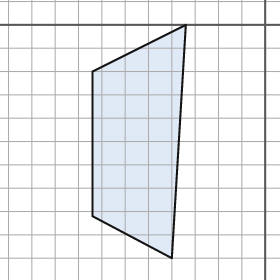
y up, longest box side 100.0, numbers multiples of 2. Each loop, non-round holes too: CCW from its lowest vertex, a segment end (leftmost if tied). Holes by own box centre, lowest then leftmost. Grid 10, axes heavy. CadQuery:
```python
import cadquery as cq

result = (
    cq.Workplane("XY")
    .moveTo(-40.0, -100.0)
    .lineTo(-34.0, 0.0)
    .lineTo(-74.0, -20.0)
    .lineTo(-74.0, -82.0)
    .close()
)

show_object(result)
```